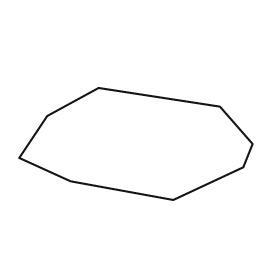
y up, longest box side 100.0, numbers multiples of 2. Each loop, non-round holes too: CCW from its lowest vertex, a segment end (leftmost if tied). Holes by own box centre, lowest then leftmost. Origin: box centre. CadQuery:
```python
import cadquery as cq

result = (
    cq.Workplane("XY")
    .moveTo(16.0, -24.0)
    .lineTo(46.0, -10.0)
    .lineTo(50.0, 0.0)
    .lineTo(36.0, 16.0)
    .lineTo(-16.0, 24.0)
    .lineTo(-38.0, 12.0)
    .lineTo(-50.0, -6.0)
    .lineTo(-28.0, -16.0)
    .close()
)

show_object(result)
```